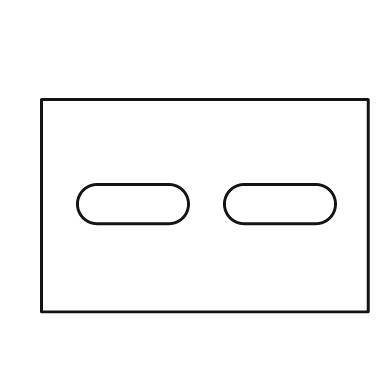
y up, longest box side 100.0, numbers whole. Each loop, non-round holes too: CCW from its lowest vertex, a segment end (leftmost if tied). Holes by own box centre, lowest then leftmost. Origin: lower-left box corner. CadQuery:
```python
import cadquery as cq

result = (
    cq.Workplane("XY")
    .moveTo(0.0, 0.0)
    .lineTo(100.0, 0.0)
    .lineTo(100.0, 65.0)
    .lineTo(0.0, 65.0)
    .close()
    .moveTo(17.0, 27.0)
    .lineTo(39.0, 27.0)
    .threePointArc((45.0, 33.0), (39.0, 39.0))
    .lineTo(17.0, 39.0)
    .threePointArc((11.0, 33.0), (17.0, 27.0))
    .close()
    .moveTo(62.0, 27.0)
    .lineTo(84.0, 27.0)
    .threePointArc((90.0, 33.0), (84.0, 39.0))
    .lineTo(62.0, 39.0)
    .threePointArc((56.0, 33.0), (62.0, 27.0))
    .close()
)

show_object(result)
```